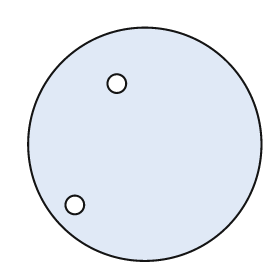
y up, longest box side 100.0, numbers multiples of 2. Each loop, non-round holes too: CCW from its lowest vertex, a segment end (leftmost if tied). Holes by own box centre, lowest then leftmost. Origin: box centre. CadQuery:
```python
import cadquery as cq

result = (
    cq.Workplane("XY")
    .moveTo(0.0, 0.0)
    .circle(50.0)
    .moveTo(-30.0, -26.0)
    .circle(4.0)
    .moveTo(-12.0, 26.0)
    .circle(4.0)
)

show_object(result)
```